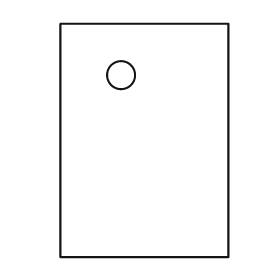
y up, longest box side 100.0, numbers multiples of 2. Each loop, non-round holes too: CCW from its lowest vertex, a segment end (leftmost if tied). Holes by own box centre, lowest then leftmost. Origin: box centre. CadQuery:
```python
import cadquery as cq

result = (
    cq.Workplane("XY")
    .moveTo(-36.0, -50.0)
    .lineTo(36.0, -50.0)
    .lineTo(36.0, 50.0)
    .lineTo(-36.0, 50.0)
    .close()
    .moveTo(-10.0, 28.0)
    .circle(6.0)
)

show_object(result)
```